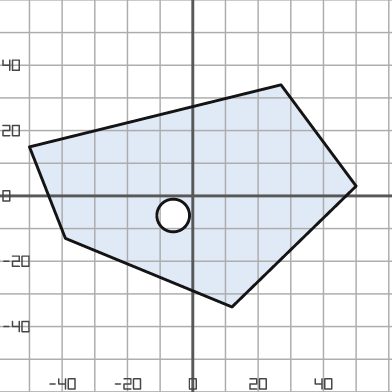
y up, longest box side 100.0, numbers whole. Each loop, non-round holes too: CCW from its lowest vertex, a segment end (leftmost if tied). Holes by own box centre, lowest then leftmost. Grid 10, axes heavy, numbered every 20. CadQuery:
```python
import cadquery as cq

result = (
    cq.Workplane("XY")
    .moveTo(12.0, -34.0)
    .lineTo(50.0, 3.0)
    .lineTo(27.0, 34.0)
    .lineTo(-50.0, 15.0)
    .lineTo(-39.0, -13.0)
    .close()
    .moveTo(-6.0, -6.0)
    .circle(5.0)
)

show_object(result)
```